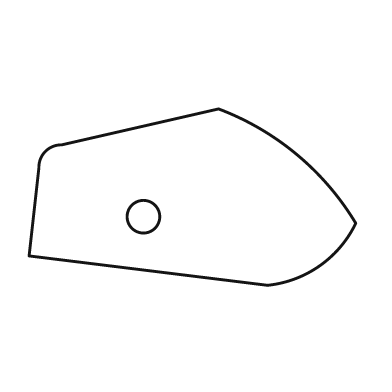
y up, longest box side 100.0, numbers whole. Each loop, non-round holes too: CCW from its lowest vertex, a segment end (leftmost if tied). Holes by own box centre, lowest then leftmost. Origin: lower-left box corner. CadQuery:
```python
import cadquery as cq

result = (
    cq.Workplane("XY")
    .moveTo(73.0, 0.0)
    .threePointArc((89.0, 6.0), (100.0, 19.0))
    .threePointArc((82.0, 40.0), (58.0, 54.0))
    .lineTo(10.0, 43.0)
    .threePointArc((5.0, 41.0), (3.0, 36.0))
    .lineTo(0.0, 9.0)
    .close()
    .moveTo(35.0, 21.0)
    .circle(5.0)
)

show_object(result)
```